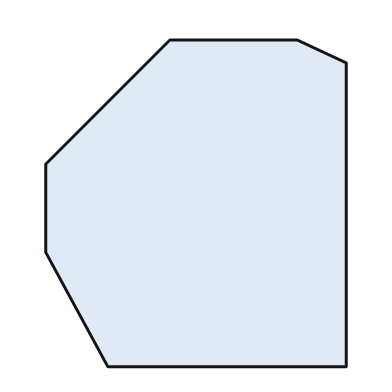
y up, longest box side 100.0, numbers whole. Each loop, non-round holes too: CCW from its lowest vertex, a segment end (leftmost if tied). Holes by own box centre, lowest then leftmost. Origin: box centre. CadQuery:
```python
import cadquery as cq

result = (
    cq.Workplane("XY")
    .moveTo(-27.0, -50.0)
    .lineTo(46.0, -50.0)
    .lineTo(46.0, 43.0)
    .lineTo(31.0, 50.0)
    .lineTo(-8.0, 50.0)
    .lineTo(-46.0, 12.0)
    .lineTo(-46.0, -15.0)
    .close()
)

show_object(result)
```